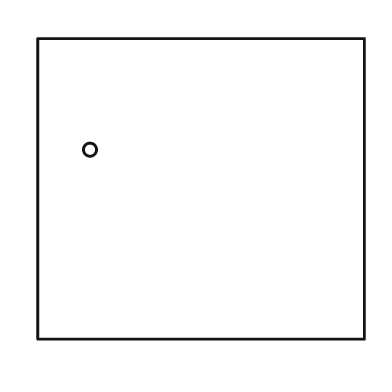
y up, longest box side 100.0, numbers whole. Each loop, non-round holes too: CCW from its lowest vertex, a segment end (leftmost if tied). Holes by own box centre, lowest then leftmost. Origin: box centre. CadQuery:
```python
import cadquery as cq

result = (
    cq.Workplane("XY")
    .moveTo(-50.0, -46.0)
    .lineTo(50.0, -46.0)
    .lineTo(50.0, 46.0)
    .lineTo(-50.0, 46.0)
    .close()
    .moveTo(-34.0, 12.0)
    .circle(2.0)
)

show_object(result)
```